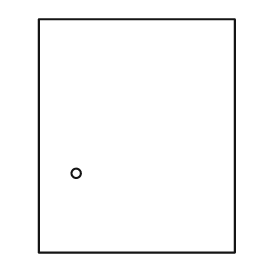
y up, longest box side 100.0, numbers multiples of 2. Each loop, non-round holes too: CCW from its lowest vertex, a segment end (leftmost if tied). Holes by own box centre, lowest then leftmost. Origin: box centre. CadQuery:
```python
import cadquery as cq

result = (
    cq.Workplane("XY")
    .moveTo(-42.0, -50.0)
    .lineTo(42.0, -50.0)
    .lineTo(42.0, 50.0)
    .lineTo(-42.0, 50.0)
    .close()
    .moveTo(-26.0, -16.0)
    .circle(2.0)
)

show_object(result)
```